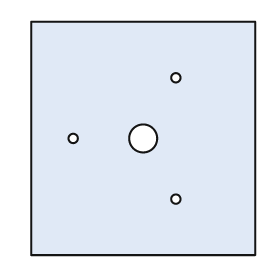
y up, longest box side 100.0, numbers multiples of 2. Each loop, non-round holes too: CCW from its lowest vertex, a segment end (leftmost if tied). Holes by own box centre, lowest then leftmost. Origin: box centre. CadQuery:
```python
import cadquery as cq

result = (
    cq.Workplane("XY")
    .moveTo(-48.0, -50.0)
    .lineTo(48.0, -50.0)
    .lineTo(48.0, 50.0)
    .lineTo(-48.0, 50.0)
    .close()
    .moveTo(14.0, -26.0)
    .circle(2.0)
    .moveTo(-30.0, 0.0)
    .circle(2.0)
    .moveTo(0.0, 0.0)
    .circle(6.0)
    .moveTo(14.0, 26.0)
    .circle(2.0)
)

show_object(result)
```